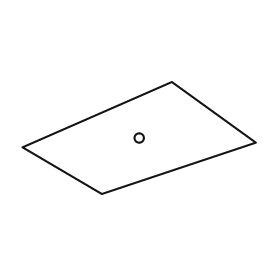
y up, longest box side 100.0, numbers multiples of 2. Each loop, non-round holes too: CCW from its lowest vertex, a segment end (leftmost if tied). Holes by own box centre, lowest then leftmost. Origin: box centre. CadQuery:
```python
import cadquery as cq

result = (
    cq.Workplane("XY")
    .moveTo(-16.0, -24.0)
    .lineTo(50.0, -2.0)
    .lineTo(14.0, 24.0)
    .lineTo(-50.0, -4.0)
    .close()
    .moveTo(0.0, 0.0)
    .circle(2.0)
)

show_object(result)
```